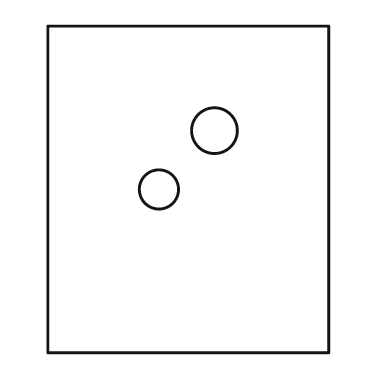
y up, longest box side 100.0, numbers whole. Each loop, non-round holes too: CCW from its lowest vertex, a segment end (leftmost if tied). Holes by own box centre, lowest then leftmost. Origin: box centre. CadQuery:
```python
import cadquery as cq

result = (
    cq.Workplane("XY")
    .moveTo(-43.0, -50.0)
    .lineTo(43.0, -50.0)
    .lineTo(43.0, 50.0)
    .lineTo(-43.0, 50.0)
    .close()
    .moveTo(-9.0, 0.0)
    .circle(6.0)
    .moveTo(8.0, 18.0)
    .circle(7.0)
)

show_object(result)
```